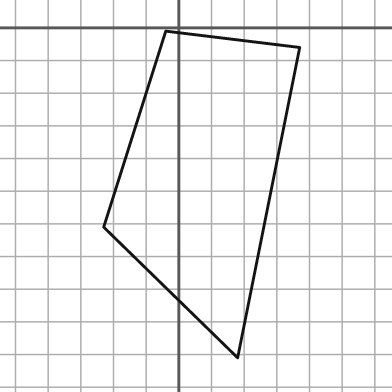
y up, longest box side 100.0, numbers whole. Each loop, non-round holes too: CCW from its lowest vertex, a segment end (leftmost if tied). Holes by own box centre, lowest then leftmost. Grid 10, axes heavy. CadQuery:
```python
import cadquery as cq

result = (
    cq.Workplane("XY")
    .moveTo(18.0, -101.0)
    .lineTo(37.0, -6.0)
    .lineTo(-4.0, -1.0)
    .lineTo(-23.0, -61.0)
    .close()
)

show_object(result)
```